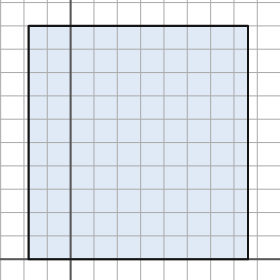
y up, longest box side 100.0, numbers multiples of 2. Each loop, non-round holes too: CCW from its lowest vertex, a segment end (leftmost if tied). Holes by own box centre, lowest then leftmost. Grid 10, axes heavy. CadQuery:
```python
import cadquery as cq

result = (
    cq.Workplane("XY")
    .moveTo(-18.0, 0.0)
    .lineTo(76.0, 0.0)
    .lineTo(76.0, 100.0)
    .lineTo(-18.0, 100.0)
    .close()
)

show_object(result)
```